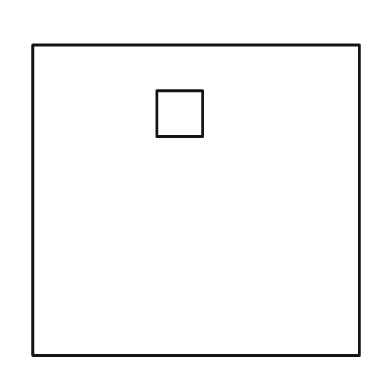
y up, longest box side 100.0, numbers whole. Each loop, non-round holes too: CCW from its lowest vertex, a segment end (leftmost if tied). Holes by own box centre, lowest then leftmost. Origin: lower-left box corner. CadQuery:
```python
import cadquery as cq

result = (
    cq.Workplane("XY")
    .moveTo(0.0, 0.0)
    .lineTo(100.0, 0.0)
    .lineTo(100.0, 95.0)
    .lineTo(0.0, 95.0)
    .close()
    .moveTo(38.0, 67.0)
    .lineTo(52.0, 67.0)
    .lineTo(52.0, 81.0)
    .lineTo(38.0, 81.0)
    .close()
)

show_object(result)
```